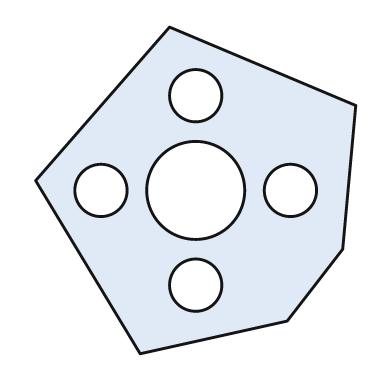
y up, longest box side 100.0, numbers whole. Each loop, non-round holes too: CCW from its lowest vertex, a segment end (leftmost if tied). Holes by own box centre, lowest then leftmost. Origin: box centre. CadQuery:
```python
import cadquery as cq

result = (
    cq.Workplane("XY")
    .moveTo(-17.0, -50.0)
    .lineTo(28.0, -40.0)
    .lineTo(45.0, -18.0)
    .lineTo(49.0, 26.0)
    .lineTo(-8.0, 50.0)
    .lineTo(-49.0, 3.0)
    .close()
    .moveTo(0.0, -29.0)
    .circle(8.0)
    .moveTo(-29.0, 0.0)
    .circle(8.0)
    .moveTo(0.0, 0.0)
    .circle(15.0)
    .moveTo(29.0, 0.0)
    .circle(8.0)
    .moveTo(0.0, 29.0)
    .circle(8.0)
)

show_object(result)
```